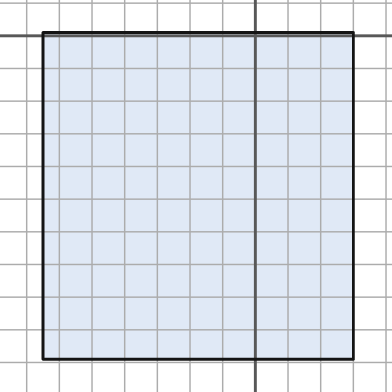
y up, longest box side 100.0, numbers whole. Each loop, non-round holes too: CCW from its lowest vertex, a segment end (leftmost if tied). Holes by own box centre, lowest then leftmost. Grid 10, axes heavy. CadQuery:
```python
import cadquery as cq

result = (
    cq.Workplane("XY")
    .moveTo(-65.0, -99.0)
    .lineTo(30.0, -99.0)
    .lineTo(30.0, 1.0)
    .lineTo(-65.0, 1.0)
    .close()
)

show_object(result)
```